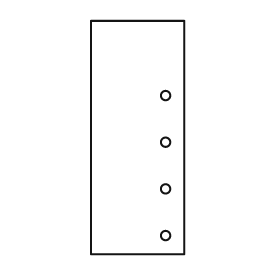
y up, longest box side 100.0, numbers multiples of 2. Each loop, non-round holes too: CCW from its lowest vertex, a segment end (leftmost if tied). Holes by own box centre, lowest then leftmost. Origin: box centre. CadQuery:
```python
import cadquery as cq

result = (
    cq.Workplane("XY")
    .moveTo(-20.0, -50.0)
    .lineTo(20.0, -50.0)
    .lineTo(20.0, 50.0)
    .lineTo(-20.0, 50.0)
    .close()
    .moveTo(12.0, -42.0)
    .circle(2.0)
    .moveTo(12.0, -22.0)
    .circle(2.0)
    .moveTo(12.0, -2.0)
    .circle(2.0)
    .moveTo(12.0, 18.0)
    .circle(2.0)
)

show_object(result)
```